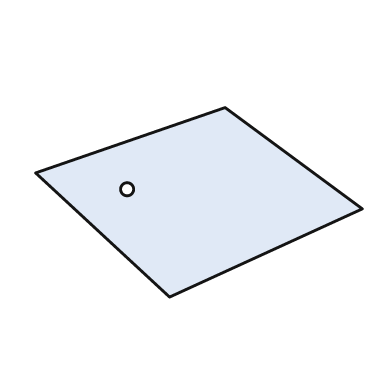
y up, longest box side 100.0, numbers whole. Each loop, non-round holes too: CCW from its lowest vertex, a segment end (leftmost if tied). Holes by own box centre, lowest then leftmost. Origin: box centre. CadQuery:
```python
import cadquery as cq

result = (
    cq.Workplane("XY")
    .moveTo(-9.0, -29.0)
    .lineTo(50.0, -2.0)
    .lineTo(8.0, 29.0)
    .lineTo(-50.0, 9.0)
    .close()
    .moveTo(-22.0, 4.0)
    .circle(2.0)
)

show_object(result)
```